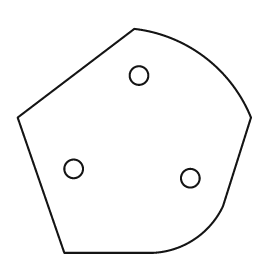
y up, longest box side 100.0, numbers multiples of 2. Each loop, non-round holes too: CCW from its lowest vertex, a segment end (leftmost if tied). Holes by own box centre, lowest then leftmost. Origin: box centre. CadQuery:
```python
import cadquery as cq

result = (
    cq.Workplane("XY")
    .moveTo(-30.0, -48.0)
    .lineTo(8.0, -48.0)
    .threePointArc((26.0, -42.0), (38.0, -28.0))
    .lineTo(50.0, 10.0)
    .threePointArc((30.0, 36.0), (0.0, 48.0))
    .lineTo(-50.0, 10.0)
    .close()
    .moveTo(24.0, -16.0)
    .circle(4.0)
    .moveTo(-26.0, -12.0)
    .circle(4.0)
    .moveTo(2.0, 28.0)
    .circle(4.0)
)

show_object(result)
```